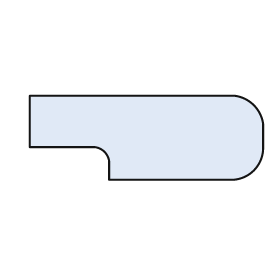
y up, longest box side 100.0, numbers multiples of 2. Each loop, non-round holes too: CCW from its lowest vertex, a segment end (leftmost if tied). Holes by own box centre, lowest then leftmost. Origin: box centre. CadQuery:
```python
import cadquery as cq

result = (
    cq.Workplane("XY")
    .moveTo(-16.0, -18.0)
    .lineTo(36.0, -18.0)
    .threePointArc((46.0, -14.0), (50.0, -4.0))
    .lineTo(50.0, 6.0)
    .threePointArc((46.0, 14.0), (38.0, 18.0))
    .lineTo(-50.0, 18.0)
    .lineTo(-50.0, -4.0)
    .lineTo(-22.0, -4.0)
    .threePointArc((-18.0, -6.0), (-16.0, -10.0))
    .close()
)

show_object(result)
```